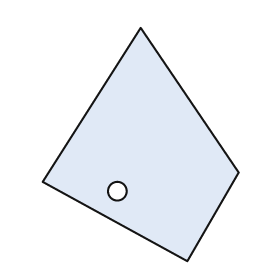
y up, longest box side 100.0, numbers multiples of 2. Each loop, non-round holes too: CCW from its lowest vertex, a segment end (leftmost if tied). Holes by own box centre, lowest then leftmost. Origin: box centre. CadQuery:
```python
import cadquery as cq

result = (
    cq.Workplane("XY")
    .moveTo(20.0, -50.0)
    .lineTo(42.0, -12.0)
    .lineTo(0.0, 50.0)
    .lineTo(-42.0, -16.0)
    .close()
    .moveTo(-10.0, -20.0)
    .circle(4.0)
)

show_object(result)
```